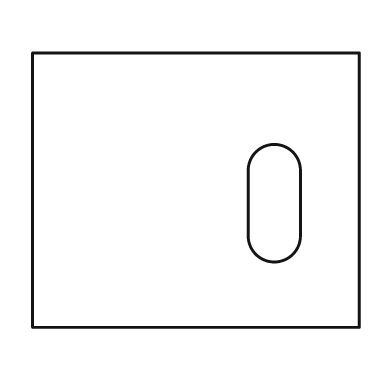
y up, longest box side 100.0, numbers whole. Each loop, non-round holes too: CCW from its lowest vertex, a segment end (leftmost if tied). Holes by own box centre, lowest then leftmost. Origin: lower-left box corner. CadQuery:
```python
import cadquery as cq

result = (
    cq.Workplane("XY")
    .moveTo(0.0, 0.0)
    .lineTo(100.0, 0.0)
    .lineTo(100.0, 84.0)
    .lineTo(0.0, 84.0)
    .close()
    .moveTo(66.0, 28.0)
    .threePointArc((74.0, 20.0), (82.0, 28.0))
    .lineTo(82.0, 48.0)
    .threePointArc((74.0, 56.0), (66.0, 48.0))
    .close()
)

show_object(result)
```